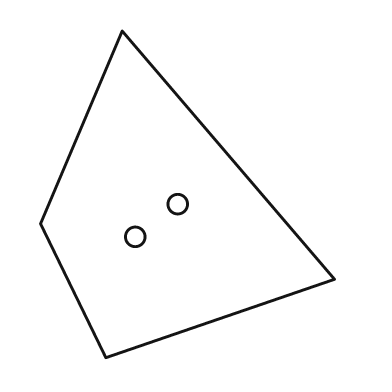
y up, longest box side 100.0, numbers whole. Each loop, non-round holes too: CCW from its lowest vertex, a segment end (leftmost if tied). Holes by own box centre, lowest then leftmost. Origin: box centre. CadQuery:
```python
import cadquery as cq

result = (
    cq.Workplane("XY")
    .moveTo(-25.0, -50.0)
    .lineTo(45.0, -26.0)
    .lineTo(-20.0, 50.0)
    .lineTo(-45.0, -9.0)
    .close()
    .moveTo(-16.0, -13.0)
    .circle(3.0)
    .moveTo(-3.0, -3.0)
    .circle(3.0)
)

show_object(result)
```